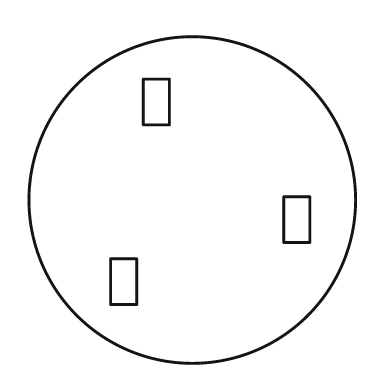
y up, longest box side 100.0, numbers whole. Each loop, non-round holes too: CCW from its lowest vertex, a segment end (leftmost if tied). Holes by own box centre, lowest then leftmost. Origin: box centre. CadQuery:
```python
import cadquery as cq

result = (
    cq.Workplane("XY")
    .moveTo(0.0, 0.0)
    .circle(50.0)
    .moveTo(-25.0, -32.0)
    .lineTo(-17.0, -32.0)
    .lineTo(-17.0, -18.0)
    .lineTo(-25.0, -18.0)
    .close()
    .moveTo(28.0, -13.0)
    .lineTo(36.0, -13.0)
    .lineTo(36.0, 1.0)
    .lineTo(28.0, 1.0)
    .close()
    .moveTo(-15.0, 23.0)
    .lineTo(-7.0, 23.0)
    .lineTo(-7.0, 37.0)
    .lineTo(-15.0, 37.0)
    .close()
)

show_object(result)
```